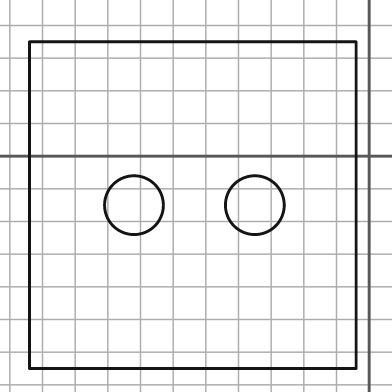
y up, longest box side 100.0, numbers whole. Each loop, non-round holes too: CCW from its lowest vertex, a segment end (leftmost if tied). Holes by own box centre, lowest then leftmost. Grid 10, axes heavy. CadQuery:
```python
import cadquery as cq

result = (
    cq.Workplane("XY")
    .moveTo(-104.0, -65.0)
    .lineTo(-4.0, -65.0)
    .lineTo(-4.0, 35.0)
    .lineTo(-104.0, 35.0)
    .close()
    .moveTo(-72.0, -15.0)
    .circle(9.0)
    .moveTo(-35.0, -15.0)
    .circle(9.0)
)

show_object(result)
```